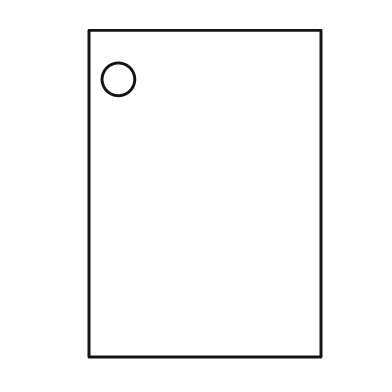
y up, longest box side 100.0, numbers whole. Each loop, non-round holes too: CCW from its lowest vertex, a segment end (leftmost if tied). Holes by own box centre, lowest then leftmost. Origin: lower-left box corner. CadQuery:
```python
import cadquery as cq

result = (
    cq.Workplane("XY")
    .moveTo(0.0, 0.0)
    .lineTo(71.0, 0.0)
    .lineTo(71.0, 100.0)
    .lineTo(0.0, 100.0)
    .close()
    .moveTo(9.0, 85.0)
    .circle(5.0)
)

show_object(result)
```